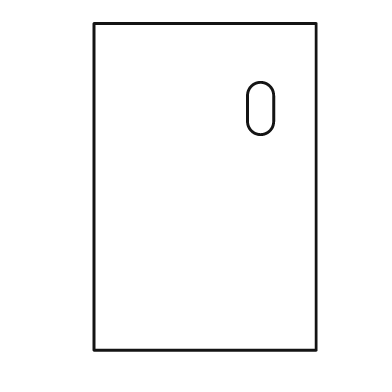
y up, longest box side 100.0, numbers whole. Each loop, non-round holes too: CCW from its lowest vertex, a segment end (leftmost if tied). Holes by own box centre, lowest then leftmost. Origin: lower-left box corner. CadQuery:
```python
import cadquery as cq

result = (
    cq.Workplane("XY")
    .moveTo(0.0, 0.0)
    .lineTo(68.0, 0.0)
    .lineTo(68.0, 100.0)
    .lineTo(0.0, 100.0)
    .close()
    .moveTo(47.0, 70.0)
    .threePointArc((51.0, 66.0), (55.0, 70.0))
    .lineTo(55.0, 78.0)
    .threePointArc((51.0, 82.0), (47.0, 78.0))
    .close()
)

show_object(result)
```